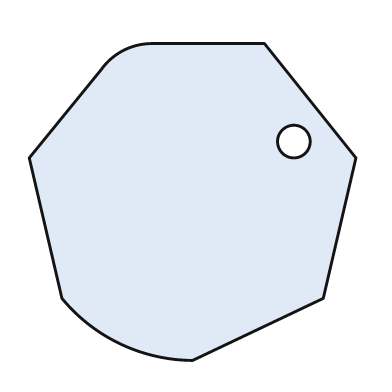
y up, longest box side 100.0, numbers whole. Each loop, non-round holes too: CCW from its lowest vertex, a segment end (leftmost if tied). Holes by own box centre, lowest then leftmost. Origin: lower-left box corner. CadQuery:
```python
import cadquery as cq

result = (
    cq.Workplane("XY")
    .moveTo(50.0, 0.0)
    .lineTo(90.0, 19.0)
    .lineTo(100.0, 62.0)
    .lineTo(72.0, 97.0)
    .lineTo(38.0, 97.0)
    .threePointArc((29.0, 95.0), (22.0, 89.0))
    .lineTo(0.0, 62.0)
    .lineTo(10.0, 19.0)
    .threePointArc((28.0, 5.0), (50.0, 0.0))
    .close()
    .moveTo(81.0, 67.0)
    .circle(5.0)
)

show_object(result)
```